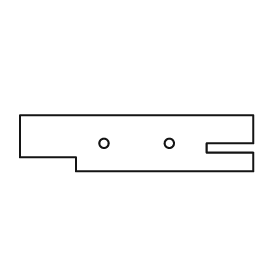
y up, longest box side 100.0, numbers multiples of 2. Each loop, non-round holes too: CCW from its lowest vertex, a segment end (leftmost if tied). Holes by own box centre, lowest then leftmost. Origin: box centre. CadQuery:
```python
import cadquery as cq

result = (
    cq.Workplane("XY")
    .moveTo(-26.0, -12.0)
    .lineTo(50.0, -12.0)
    .lineTo(50.0, -4.0)
    .lineTo(30.0, -4.0)
    .lineTo(30.0, 0.0)
    .lineTo(50.0, 0.0)
    .lineTo(50.0, 12.0)
    .lineTo(-50.0, 12.0)
    .lineTo(-50.0, -6.0)
    .lineTo(-26.0, -6.0)
    .close()
    .moveTo(-14.0, 0.0)
    .circle(2.0)
    .moveTo(14.0, 0.0)
    .circle(2.0)
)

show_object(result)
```